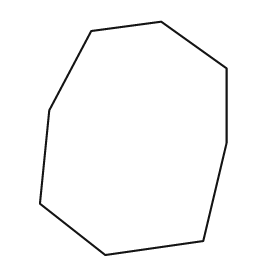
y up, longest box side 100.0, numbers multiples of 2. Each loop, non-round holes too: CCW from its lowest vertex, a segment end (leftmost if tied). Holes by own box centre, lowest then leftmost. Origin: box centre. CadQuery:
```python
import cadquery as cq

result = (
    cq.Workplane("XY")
    .moveTo(-12.0, -50.0)
    .lineTo(30.0, -44.0)
    .lineTo(40.0, -2.0)
    .lineTo(40.0, 30.0)
    .lineTo(12.0, 50.0)
    .lineTo(-18.0, 46.0)
    .lineTo(-36.0, 12.0)
    .lineTo(-40.0, -28.0)
    .close()
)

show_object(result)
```